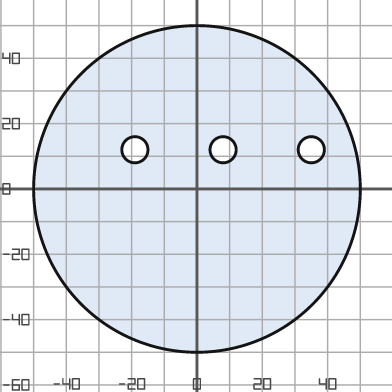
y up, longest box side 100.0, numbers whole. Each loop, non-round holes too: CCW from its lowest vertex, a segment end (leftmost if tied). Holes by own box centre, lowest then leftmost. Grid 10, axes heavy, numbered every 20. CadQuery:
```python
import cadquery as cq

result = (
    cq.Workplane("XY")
    .moveTo(0.0, 0.0)
    .circle(50.0)
    .moveTo(-19.0, 12.0)
    .circle(4.0)
    .moveTo(8.0, 12.0)
    .circle(4.0)
    .moveTo(35.0, 12.0)
    .circle(4.0)
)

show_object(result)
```